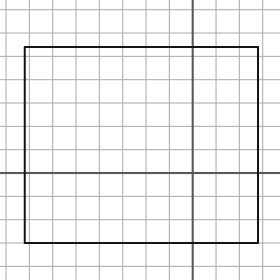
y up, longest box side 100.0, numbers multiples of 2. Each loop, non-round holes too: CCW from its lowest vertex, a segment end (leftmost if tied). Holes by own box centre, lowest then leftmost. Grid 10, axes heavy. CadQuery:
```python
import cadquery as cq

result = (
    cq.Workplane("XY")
    .moveTo(-72.0, -30.0)
    .lineTo(28.0, -30.0)
    .lineTo(28.0, 54.0)
    .lineTo(-72.0, 54.0)
    .close()
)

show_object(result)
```